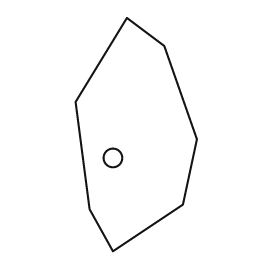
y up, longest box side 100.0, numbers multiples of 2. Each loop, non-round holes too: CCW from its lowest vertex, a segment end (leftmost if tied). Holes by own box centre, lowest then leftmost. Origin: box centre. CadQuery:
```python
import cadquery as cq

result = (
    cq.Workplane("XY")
    .moveTo(-10.0, -50.0)
    .lineTo(20.0, -30.0)
    .lineTo(26.0, -2.0)
    .lineTo(12.0, 38.0)
    .lineTo(-4.0, 50.0)
    .lineTo(-26.0, 14.0)
    .lineTo(-20.0, -32.0)
    .close()
    .moveTo(-10.0, -10.0)
    .circle(4.0)
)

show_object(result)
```